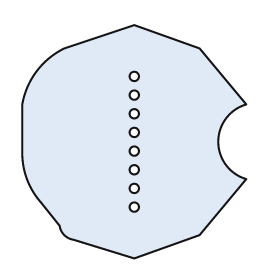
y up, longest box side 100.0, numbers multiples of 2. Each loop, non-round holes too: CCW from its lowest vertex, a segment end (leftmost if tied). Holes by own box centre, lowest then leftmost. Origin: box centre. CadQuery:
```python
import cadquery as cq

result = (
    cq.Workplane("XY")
    .moveTo(0.0, -50.0)
    .lineTo(28.0, -40.0)
    .lineTo(48.0, -16.0)
    .threePointArc((36.0, 0.0), (48.0, 16.0))
    .lineTo(28.0, 40.0)
    .lineTo(0.0, 50.0)
    .lineTo(-30.0, 40.0)
    .threePointArc((-42.0, 30.0), (-48.0, 16.0))
    .lineTo(-48.0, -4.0)
    .threePointArc((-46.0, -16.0), (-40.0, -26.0))
    .lineTo(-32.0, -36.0)
    .threePointArc((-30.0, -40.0), (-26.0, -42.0))
    .close()
    .moveTo(0.0, -28.0)
    .circle(2.0)
    .moveTo(0.0, -20.0)
    .circle(2.0)
    .moveTo(0.0, -12.0)
    .circle(2.0)
    .moveTo(0.0, -4.0)
    .circle(2.0)
    .moveTo(0.0, 4.0)
    .circle(2.0)
    .moveTo(0.0, 12.0)
    .circle(2.0)
    .moveTo(0.0, 20.0)
    .circle(2.0)
    .moveTo(0.0, 28.0)
    .circle(2.0)
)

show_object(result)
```